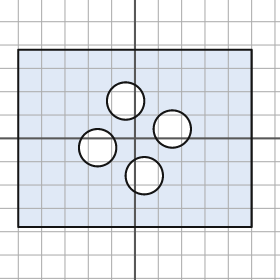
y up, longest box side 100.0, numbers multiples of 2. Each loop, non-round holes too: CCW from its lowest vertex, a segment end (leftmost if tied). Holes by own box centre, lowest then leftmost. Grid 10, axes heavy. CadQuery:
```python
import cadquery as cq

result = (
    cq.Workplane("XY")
    .moveTo(-50.0, -38.0)
    .lineTo(50.0, -38.0)
    .lineTo(50.0, 38.0)
    .lineTo(-50.0, 38.0)
    .close()
    .moveTo(4.0, -16.0)
    .circle(8.0)
    .moveTo(-16.0, -4.0)
    .circle(8.0)
    .moveTo(16.0, 4.0)
    .circle(8.0)
    .moveTo(-4.0, 16.0)
    .circle(8.0)
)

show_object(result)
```